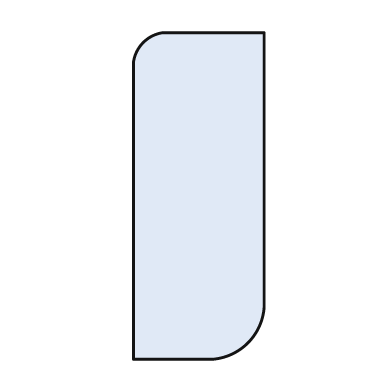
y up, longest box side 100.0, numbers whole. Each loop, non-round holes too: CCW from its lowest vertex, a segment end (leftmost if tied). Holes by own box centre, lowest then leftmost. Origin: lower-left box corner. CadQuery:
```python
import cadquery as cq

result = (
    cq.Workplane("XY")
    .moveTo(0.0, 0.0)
    .lineTo(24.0, 0.0)
    .threePointArc((35.0, 5.0), (40.0, 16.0))
    .lineTo(40.0, 100.0)
    .lineTo(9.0, 100.0)
    .threePointArc((3.0, 97.0), (0.0, 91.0))
    .close()
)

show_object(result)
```